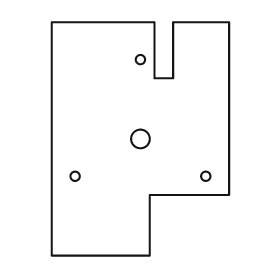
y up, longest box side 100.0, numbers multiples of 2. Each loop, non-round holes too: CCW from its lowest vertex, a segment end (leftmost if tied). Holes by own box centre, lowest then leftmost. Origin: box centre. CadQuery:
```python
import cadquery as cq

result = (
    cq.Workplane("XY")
    .moveTo(-38.0, -50.0)
    .lineTo(4.0, -50.0)
    .lineTo(4.0, -24.0)
    .lineTo(38.0, -24.0)
    .lineTo(38.0, 50.0)
    .lineTo(14.0, 50.0)
    .lineTo(14.0, 26.0)
    .lineTo(6.0, 26.0)
    .lineTo(6.0, 50.0)
    .lineTo(-38.0, 50.0)
    .close()
    .moveTo(-28.0, -16.0)
    .circle(2.0)
    .moveTo(28.0, -16.0)
    .circle(2.0)
    .moveTo(0.0, 0.0)
    .circle(4.0)
    .moveTo(0.0, 34.0)
    .circle(2.0)
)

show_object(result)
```